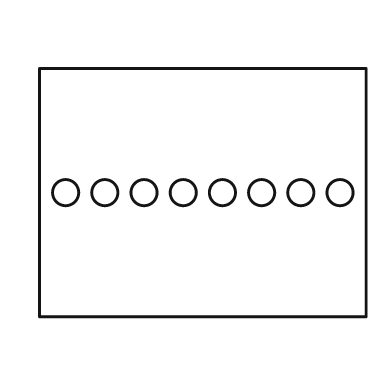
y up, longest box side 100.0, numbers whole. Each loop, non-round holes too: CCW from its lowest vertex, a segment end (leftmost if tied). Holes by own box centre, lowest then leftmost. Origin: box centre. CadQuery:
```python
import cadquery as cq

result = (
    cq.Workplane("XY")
    .moveTo(-50.0, -38.0)
    .lineTo(50.0, -38.0)
    .lineTo(50.0, 38.0)
    .lineTo(-50.0, 38.0)
    .close()
    .moveTo(-42.0, 0.0)
    .circle(4.0)
    .moveTo(-30.0, 0.0)
    .circle(4.0)
    .moveTo(-18.0, 0.0)
    .circle(4.0)
    .moveTo(-6.0, 0.0)
    .circle(4.0)
    .moveTo(6.0, 0.0)
    .circle(4.0)
    .moveTo(18.0, 0.0)
    .circle(4.0)
    .moveTo(30.0, 0.0)
    .circle(4.0)
    .moveTo(42.0, 0.0)
    .circle(4.0)
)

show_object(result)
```